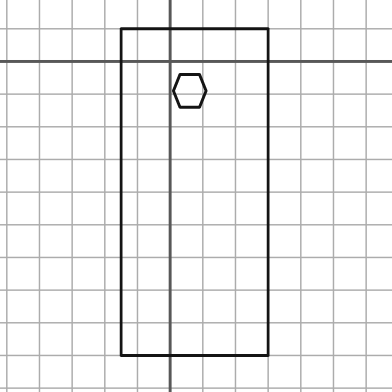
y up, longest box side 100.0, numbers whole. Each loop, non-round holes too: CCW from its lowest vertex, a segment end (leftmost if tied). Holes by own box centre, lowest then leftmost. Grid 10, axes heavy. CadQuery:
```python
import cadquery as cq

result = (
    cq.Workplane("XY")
    .moveTo(-15.0, -90.0)
    .lineTo(30.0, -90.0)
    .lineTo(30.0, 10.0)
    .lineTo(-15.0, 10.0)
    .close()
    .moveTo(3.0, -14.0)
    .lineTo(9.0, -14.0)
    .lineTo(11.0, -9.0)
    .lineTo(9.0, -4.0)
    .lineTo(3.0, -4.0)
    .lineTo(1.0, -9.0)
    .close()
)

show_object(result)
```